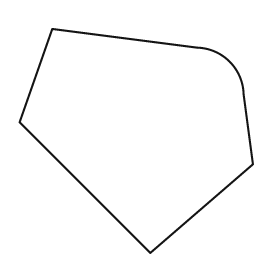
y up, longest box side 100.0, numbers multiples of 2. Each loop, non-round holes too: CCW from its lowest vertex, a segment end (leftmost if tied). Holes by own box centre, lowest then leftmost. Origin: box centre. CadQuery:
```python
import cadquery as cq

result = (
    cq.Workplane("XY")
    .moveTo(6.0, -48.0)
    .lineTo(50.0, -10.0)
    .lineTo(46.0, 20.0)
    .threePointArc((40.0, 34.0), (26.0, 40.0))
    .lineTo(-36.0, 48.0)
    .lineTo(-50.0, 8.0)
    .close()
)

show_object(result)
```